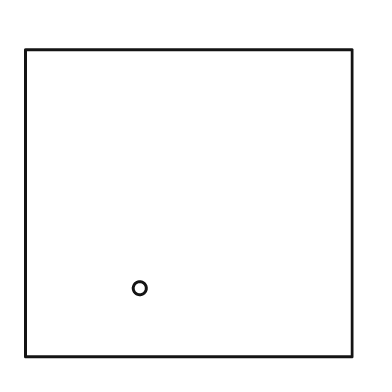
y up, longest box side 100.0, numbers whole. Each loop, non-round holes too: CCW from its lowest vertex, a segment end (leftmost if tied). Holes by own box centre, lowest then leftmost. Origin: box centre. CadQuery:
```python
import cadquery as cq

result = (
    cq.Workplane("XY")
    .moveTo(-50.0, -47.0)
    .lineTo(50.0, -47.0)
    .lineTo(50.0, 47.0)
    .lineTo(-50.0, 47.0)
    .close()
    .moveTo(-15.0, -26.0)
    .circle(2.0)
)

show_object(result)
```